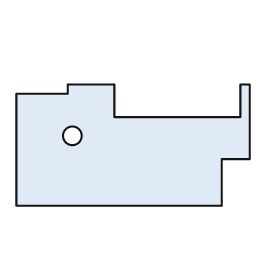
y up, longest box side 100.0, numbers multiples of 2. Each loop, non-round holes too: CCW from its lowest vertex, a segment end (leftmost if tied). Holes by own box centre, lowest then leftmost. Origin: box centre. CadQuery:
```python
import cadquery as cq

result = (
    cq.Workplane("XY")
    .moveTo(-50.0, -26.0)
    .lineTo(38.0, -26.0)
    .lineTo(38.0, -6.0)
    .lineTo(50.0, -6.0)
    .lineTo(50.0, 26.0)
    .lineTo(46.0, 26.0)
    .lineTo(46.0, 12.0)
    .lineTo(-8.0, 12.0)
    .lineTo(-8.0, 26.0)
    .lineTo(-28.0, 26.0)
    .lineTo(-28.0, 22.0)
    .lineTo(-50.0, 22.0)
    .close()
    .moveTo(-26.0, 4.0)
    .circle(4.0)
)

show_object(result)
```